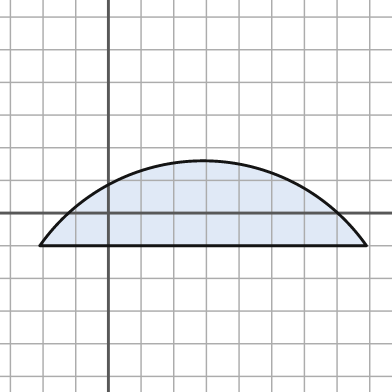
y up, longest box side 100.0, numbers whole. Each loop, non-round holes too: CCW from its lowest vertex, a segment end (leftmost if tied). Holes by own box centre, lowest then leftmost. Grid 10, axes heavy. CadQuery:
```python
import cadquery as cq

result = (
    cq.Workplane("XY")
    .moveTo(-21.0, -10.0)
    .lineTo(79.0, -10.0)
    .threePointArc((29.0, 16.0), (-21.0, -10.0))
    .close()
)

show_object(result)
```